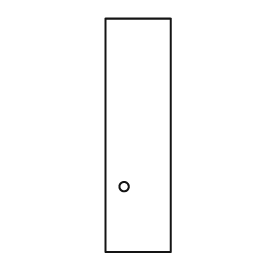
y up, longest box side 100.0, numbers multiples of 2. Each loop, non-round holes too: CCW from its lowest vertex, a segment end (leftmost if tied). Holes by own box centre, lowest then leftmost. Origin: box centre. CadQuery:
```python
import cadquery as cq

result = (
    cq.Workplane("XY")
    .moveTo(-14.0, -50.0)
    .lineTo(14.0, -50.0)
    .lineTo(14.0, 50.0)
    .lineTo(-14.0, 50.0)
    .close()
    .moveTo(-6.0, -22.0)
    .circle(2.0)
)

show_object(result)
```